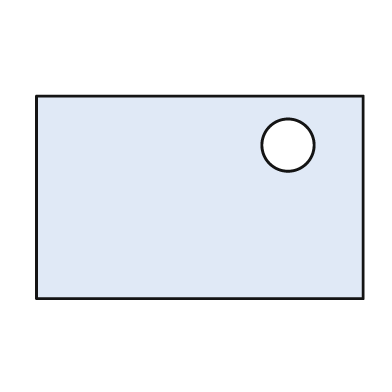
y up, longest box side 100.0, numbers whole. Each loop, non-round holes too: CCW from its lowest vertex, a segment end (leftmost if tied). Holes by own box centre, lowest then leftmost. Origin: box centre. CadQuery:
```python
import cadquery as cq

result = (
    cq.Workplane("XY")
    .moveTo(-50.0, -31.0)
    .lineTo(50.0, -31.0)
    .lineTo(50.0, 31.0)
    .lineTo(-50.0, 31.0)
    .close()
    .moveTo(27.0, 16.0)
    .circle(8.0)
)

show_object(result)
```